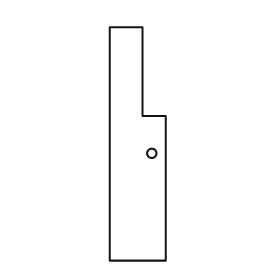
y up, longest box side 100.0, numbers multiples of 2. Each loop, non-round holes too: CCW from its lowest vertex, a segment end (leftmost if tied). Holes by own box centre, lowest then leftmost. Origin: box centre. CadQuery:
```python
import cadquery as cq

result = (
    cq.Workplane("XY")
    .moveTo(-12.0, -50.0)
    .lineTo(12.0, -50.0)
    .lineTo(12.0, 12.0)
    .lineTo(2.0, 12.0)
    .lineTo(2.0, 50.0)
    .lineTo(-12.0, 50.0)
    .close()
    .moveTo(6.0, -4.0)
    .circle(2.0)
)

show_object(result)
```